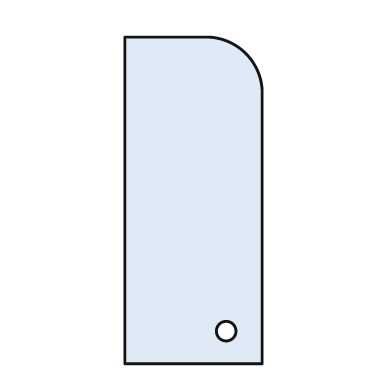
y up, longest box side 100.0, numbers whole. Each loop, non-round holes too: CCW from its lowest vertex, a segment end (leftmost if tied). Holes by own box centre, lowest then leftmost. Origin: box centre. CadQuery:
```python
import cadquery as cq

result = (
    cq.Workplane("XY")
    .moveTo(-21.0, -50.0)
    .lineTo(21.0, -50.0)
    .lineTo(21.0, 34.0)
    .threePointArc((16.0, 45.0), (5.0, 50.0))
    .lineTo(-21.0, 50.0)
    .close()
    .moveTo(10.0, -40.0)
    .circle(3.0)
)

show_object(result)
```